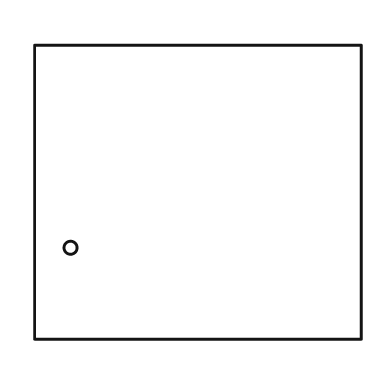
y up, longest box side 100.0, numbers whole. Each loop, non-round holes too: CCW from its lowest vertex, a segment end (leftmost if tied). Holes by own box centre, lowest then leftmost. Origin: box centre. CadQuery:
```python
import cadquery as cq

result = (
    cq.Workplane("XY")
    .moveTo(-50.0, -45.0)
    .lineTo(50.0, -45.0)
    .lineTo(50.0, 45.0)
    .lineTo(-50.0, 45.0)
    .close()
    .moveTo(-39.0, -17.0)
    .circle(2.0)
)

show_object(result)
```